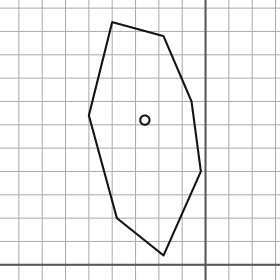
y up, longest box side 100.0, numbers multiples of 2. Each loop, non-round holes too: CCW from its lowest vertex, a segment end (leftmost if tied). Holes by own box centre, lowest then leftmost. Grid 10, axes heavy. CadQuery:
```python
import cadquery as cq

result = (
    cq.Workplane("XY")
    .moveTo(-18.0, 4.0)
    .lineTo(-2.0, 40.0)
    .lineTo(-6.0, 70.0)
    .lineTo(-18.0, 98.0)
    .lineTo(-40.0, 104.0)
    .lineTo(-50.0, 64.0)
    .lineTo(-38.0, 20.0)
    .close()
    .moveTo(-26.0, 62.0)
    .circle(2.0)
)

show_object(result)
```